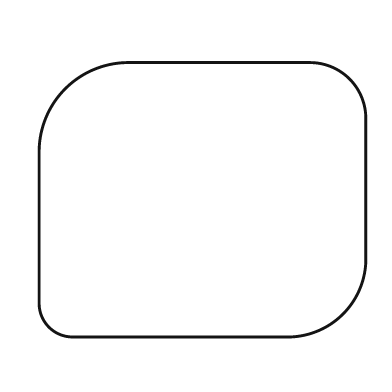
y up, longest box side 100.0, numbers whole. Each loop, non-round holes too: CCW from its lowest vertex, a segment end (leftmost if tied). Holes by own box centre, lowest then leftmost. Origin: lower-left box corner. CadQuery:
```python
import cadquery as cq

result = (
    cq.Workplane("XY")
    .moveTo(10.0, 0.0)
    .lineTo(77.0, 0.0)
    .threePointArc((93.0, 7.0), (100.0, 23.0))
    .lineTo(100.0, 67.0)
    .threePointArc((95.0, 79.0), (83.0, 84.0))
    .lineTo(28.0, 84.0)
    .threePointArc((8.0, 76.0), (0.0, 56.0))
    .lineTo(0.0, 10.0)
    .threePointArc((3.0, 3.0), (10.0, 0.0))
    .close()
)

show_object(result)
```